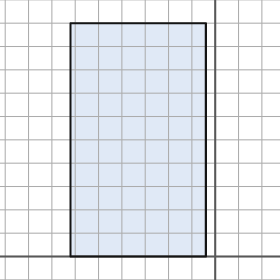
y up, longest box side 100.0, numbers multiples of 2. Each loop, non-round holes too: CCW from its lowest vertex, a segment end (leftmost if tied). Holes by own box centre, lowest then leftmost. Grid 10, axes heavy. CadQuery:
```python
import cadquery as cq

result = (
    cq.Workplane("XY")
    .moveTo(-62.0, 0.0)
    .lineTo(-4.0, 0.0)
    .lineTo(-4.0, 100.0)
    .lineTo(-62.0, 100.0)
    .close()
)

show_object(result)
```